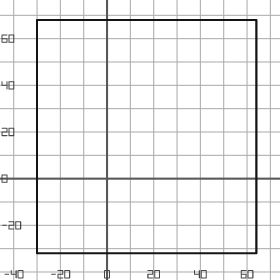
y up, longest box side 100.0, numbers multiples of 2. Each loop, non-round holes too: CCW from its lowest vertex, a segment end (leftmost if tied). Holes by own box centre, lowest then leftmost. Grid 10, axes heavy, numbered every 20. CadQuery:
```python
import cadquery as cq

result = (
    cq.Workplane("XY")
    .moveTo(-30.0, -32.0)
    .lineTo(64.0, -32.0)
    .lineTo(64.0, 68.0)
    .lineTo(-30.0, 68.0)
    .close()
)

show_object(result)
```